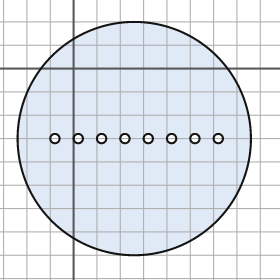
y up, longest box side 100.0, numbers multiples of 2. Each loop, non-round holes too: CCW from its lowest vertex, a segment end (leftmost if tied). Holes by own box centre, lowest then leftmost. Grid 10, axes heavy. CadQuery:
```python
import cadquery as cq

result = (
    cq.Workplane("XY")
    .moveTo(26.0, -30.0)
    .circle(50.0)
    .moveTo(-8.0, -30.0)
    .circle(2.0)
    .moveTo(2.0, -30.0)
    .circle(2.0)
    .moveTo(12.0, -30.0)
    .circle(2.0)
    .moveTo(22.0, -30.0)
    .circle(2.0)
    .moveTo(32.0, -30.0)
    .circle(2.0)
    .moveTo(42.0, -30.0)
    .circle(2.0)
    .moveTo(52.0, -30.0)
    .circle(2.0)
    .moveTo(62.0, -30.0)
    .circle(2.0)
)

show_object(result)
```